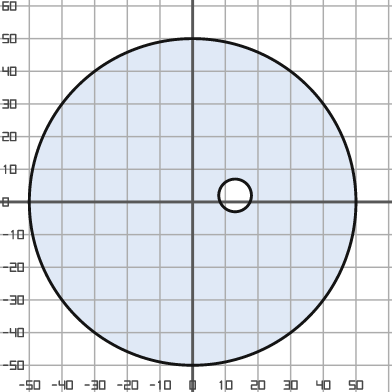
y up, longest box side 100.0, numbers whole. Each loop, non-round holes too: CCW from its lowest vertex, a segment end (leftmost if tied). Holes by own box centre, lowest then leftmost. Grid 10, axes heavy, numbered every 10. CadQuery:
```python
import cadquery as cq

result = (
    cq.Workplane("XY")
    .moveTo(0.0, 0.0)
    .circle(50.0)
    .moveTo(13.0, 2.0)
    .circle(5.0)
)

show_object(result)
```